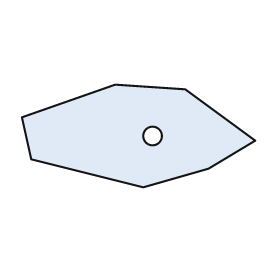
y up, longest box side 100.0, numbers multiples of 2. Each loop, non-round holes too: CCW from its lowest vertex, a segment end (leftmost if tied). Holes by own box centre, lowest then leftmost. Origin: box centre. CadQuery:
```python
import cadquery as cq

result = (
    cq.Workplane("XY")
    .moveTo(2.0, -22.0)
    .lineTo(30.0, -14.0)
    .lineTo(50.0, -2.0)
    .lineTo(20.0, 20.0)
    .lineTo(-10.0, 22.0)
    .lineTo(-50.0, 8.0)
    .lineTo(-46.0, -10.0)
    .close()
    .moveTo(6.0, 0.0)
    .circle(4.0)
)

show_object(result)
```